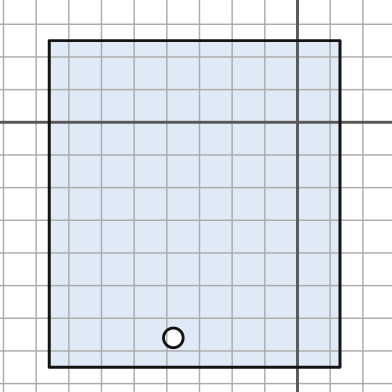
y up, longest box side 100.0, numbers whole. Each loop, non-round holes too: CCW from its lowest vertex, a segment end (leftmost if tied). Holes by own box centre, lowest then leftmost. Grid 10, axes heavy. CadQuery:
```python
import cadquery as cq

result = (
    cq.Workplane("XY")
    .moveTo(-76.0, -75.0)
    .lineTo(13.0, -75.0)
    .lineTo(13.0, 25.0)
    .lineTo(-76.0, 25.0)
    .close()
    .moveTo(-38.0, -66.0)
    .circle(3.0)
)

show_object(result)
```